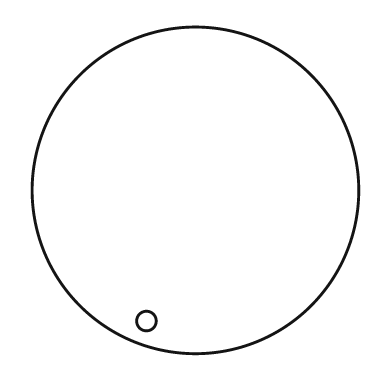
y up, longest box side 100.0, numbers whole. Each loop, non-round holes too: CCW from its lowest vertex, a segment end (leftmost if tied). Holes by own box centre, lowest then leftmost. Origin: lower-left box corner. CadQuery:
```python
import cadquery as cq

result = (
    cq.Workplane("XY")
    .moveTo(50.0, 50.0)
    .circle(50.0)
    .moveTo(35.0, 10.0)
    .circle(3.0)
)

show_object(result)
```